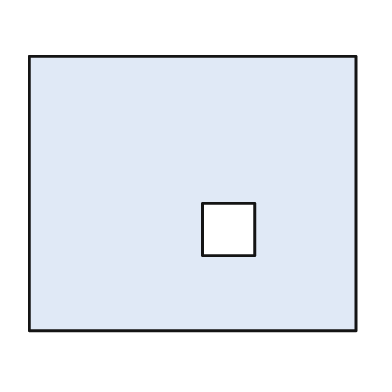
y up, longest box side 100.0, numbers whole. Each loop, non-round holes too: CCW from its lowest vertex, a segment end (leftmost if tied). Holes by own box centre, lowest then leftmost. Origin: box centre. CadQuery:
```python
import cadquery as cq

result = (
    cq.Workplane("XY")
    .moveTo(-50.0, -42.0)
    .lineTo(50.0, -42.0)
    .lineTo(50.0, 42.0)
    .lineTo(-50.0, 42.0)
    .close()
    .moveTo(3.0, -19.0)
    .lineTo(19.0, -19.0)
    .lineTo(19.0, -3.0)
    .lineTo(3.0, -3.0)
    .close()
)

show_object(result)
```